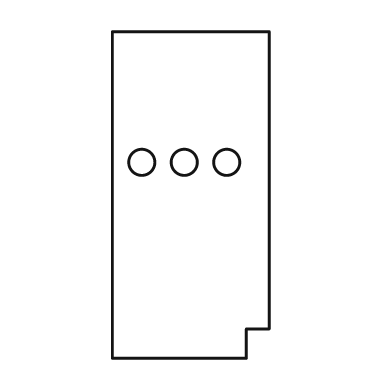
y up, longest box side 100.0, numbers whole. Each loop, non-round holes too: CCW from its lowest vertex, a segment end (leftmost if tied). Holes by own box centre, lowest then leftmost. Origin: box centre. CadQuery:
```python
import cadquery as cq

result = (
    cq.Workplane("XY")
    .moveTo(-24.0, -50.0)
    .lineTo(17.0, -50.0)
    .lineTo(17.0, -41.0)
    .lineTo(24.0, -41.0)
    .lineTo(24.0, 50.0)
    .lineTo(-24.0, 50.0)
    .close()
    .moveTo(-15.0, 10.0)
    .circle(4.0)
    .moveTo(-2.0, 10.0)
    .circle(4.0)
    .moveTo(11.0, 10.0)
    .circle(4.0)
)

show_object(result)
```